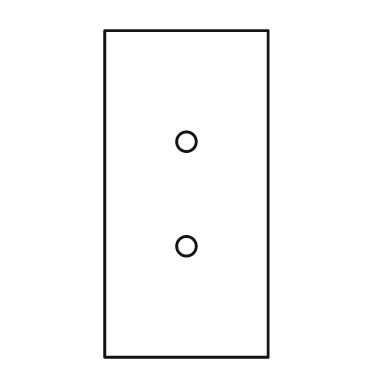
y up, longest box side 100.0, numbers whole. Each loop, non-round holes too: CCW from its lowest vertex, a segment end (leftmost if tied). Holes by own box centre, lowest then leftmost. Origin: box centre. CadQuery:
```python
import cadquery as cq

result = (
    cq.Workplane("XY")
    .moveTo(-25.0, -50.0)
    .lineTo(25.0, -50.0)
    .lineTo(25.0, 50.0)
    .lineTo(-25.0, 50.0)
    .close()
    .moveTo(0.0, -16.0)
    .circle(3.0)
    .moveTo(0.0, 16.0)
    .circle(3.0)
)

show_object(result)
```